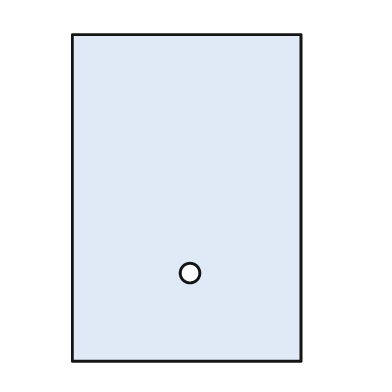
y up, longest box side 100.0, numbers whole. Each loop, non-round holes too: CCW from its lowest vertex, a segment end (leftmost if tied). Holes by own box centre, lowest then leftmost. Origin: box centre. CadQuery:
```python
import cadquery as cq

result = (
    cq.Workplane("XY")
    .moveTo(-35.0, -50.0)
    .lineTo(35.0, -50.0)
    .lineTo(35.0, 50.0)
    .lineTo(-35.0, 50.0)
    .close()
    .moveTo(1.0, -23.0)
    .circle(3.0)
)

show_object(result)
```